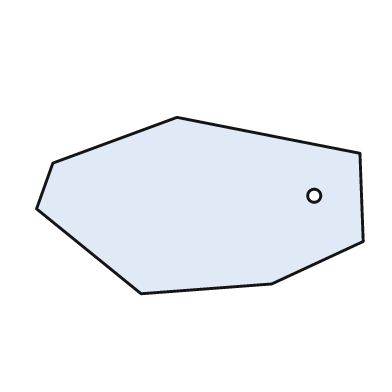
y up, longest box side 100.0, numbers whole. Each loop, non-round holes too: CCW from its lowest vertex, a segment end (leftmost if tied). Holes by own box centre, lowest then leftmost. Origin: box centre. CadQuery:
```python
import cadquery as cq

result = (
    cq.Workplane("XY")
    .moveTo(-18.0, -27.0)
    .lineTo(22.0, -24.0)
    .lineTo(50.0, -11.0)
    .lineTo(49.0, 16.0)
    .lineTo(-7.0, 27.0)
    .lineTo(-45.0, 13.0)
    .lineTo(-50.0, -1.0)
    .close()
    .moveTo(35.0, 3.0)
    .circle(2.0)
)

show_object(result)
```